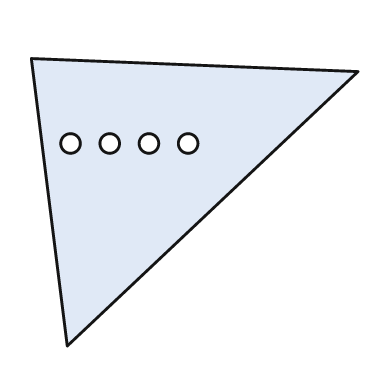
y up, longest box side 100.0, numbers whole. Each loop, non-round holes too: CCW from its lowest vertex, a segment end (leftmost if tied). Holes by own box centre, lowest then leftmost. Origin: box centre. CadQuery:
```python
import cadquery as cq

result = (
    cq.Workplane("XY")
    .moveTo(-39.0, -44.0)
    .lineTo(50.0, 40.0)
    .lineTo(-50.0, 44.0)
    .close()
    .moveTo(-38.0, 18.0)
    .circle(3.0)
    .moveTo(-26.0, 18.0)
    .circle(3.0)
    .moveTo(-14.0, 18.0)
    .circle(3.0)
    .moveTo(-2.0, 18.0)
    .circle(3.0)
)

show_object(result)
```